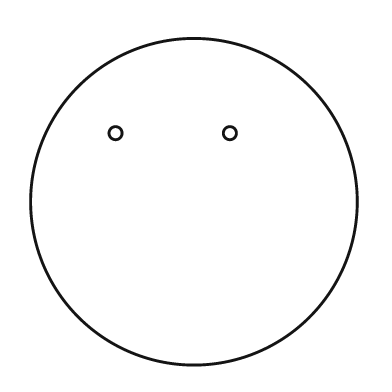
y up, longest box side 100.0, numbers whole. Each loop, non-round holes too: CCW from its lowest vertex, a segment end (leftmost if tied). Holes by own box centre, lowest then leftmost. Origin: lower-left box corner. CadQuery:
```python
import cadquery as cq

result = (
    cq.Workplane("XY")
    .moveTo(50.0, 50.0)
    .circle(50.0)
    .moveTo(26.0, 71.0)
    .circle(2.0)
    .moveTo(61.0, 71.0)
    .circle(2.0)
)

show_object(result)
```